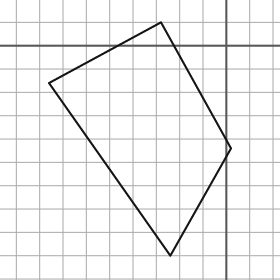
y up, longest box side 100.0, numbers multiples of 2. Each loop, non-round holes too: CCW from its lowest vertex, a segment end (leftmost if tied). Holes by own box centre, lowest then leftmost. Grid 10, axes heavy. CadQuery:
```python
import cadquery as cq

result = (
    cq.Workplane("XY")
    .moveTo(-24.0, -90.0)
    .lineTo(2.0, -44.0)
    .lineTo(-28.0, 10.0)
    .lineTo(-76.0, -16.0)
    .close()
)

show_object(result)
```